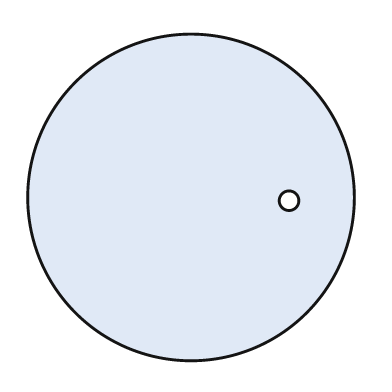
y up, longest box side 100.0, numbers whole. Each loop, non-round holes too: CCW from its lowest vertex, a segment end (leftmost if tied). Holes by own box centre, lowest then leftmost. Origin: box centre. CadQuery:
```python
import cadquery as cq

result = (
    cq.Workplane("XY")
    .moveTo(0.0, 0.0)
    .circle(50.0)
    .moveTo(30.0, -1.0)
    .circle(3.0)
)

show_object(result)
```